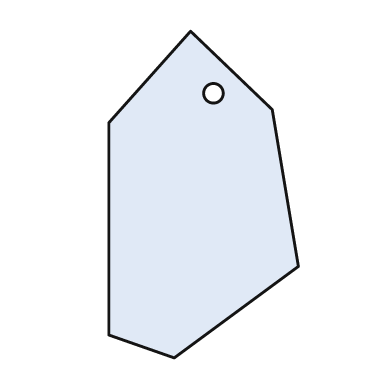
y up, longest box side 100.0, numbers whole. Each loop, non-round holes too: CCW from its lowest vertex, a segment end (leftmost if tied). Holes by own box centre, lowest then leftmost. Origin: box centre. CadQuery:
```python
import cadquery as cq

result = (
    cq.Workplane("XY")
    .moveTo(-9.0, -50.0)
    .lineTo(29.0, -22.0)
    .lineTo(21.0, 26.0)
    .lineTo(-4.0, 50.0)
    .lineTo(-29.0, 22.0)
    .lineTo(-29.0, -43.0)
    .close()
    .moveTo(3.0, 31.0)
    .circle(3.0)
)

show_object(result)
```